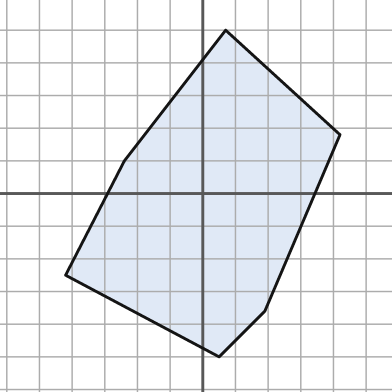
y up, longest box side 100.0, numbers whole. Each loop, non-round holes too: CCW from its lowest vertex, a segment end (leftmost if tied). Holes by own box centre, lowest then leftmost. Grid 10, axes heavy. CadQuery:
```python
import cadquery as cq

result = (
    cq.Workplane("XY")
    .moveTo(5.0, -50.0)
    .lineTo(19.0, -36.0)
    .lineTo(42.0, 18.0)
    .lineTo(7.0, 50.0)
    .lineTo(-24.0, 10.0)
    .lineTo(-42.0, -25.0)
    .close()
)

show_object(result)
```